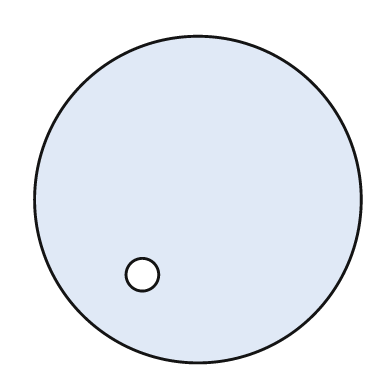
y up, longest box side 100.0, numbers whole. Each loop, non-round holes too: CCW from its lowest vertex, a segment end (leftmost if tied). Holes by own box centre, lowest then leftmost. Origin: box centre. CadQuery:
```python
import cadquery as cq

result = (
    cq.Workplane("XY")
    .moveTo(0.0, 0.0)
    .circle(50.0)
    .moveTo(-17.0, -23.0)
    .circle(5.0)
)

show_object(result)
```